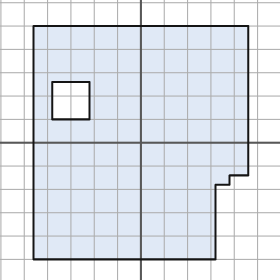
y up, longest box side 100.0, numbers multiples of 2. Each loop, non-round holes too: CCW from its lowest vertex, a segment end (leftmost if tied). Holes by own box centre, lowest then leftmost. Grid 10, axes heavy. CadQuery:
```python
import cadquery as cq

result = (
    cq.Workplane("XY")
    .moveTo(-46.0, -50.0)
    .lineTo(32.0, -50.0)
    .lineTo(32.0, -18.0)
    .lineTo(38.0, -18.0)
    .lineTo(38.0, -14.0)
    .lineTo(46.0, -14.0)
    .lineTo(46.0, 50.0)
    .lineTo(-46.0, 50.0)
    .close()
    .moveTo(-38.0, 10.0)
    .lineTo(-22.0, 10.0)
    .lineTo(-22.0, 26.0)
    .lineTo(-38.0, 26.0)
    .close()
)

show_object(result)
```